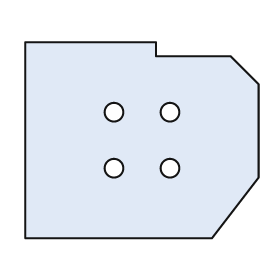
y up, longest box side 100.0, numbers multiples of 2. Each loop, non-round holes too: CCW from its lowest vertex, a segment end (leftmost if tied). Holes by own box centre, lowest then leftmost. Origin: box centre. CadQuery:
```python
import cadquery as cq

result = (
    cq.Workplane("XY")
    .moveTo(-50.0, -42.0)
    .lineTo(30.0, -42.0)
    .lineTo(50.0, -16.0)
    .lineTo(50.0, 24.0)
    .lineTo(38.0, 36.0)
    .lineTo(6.0, 36.0)
    .lineTo(6.0, 42.0)
    .lineTo(-50.0, 42.0)
    .close()
    .moveTo(-12.0, -12.0)
    .circle(4.0)
    .moveTo(12.0, -12.0)
    .circle(4.0)
    .moveTo(-12.0, 12.0)
    .circle(4.0)
    .moveTo(12.0, 12.0)
    .circle(4.0)
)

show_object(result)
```